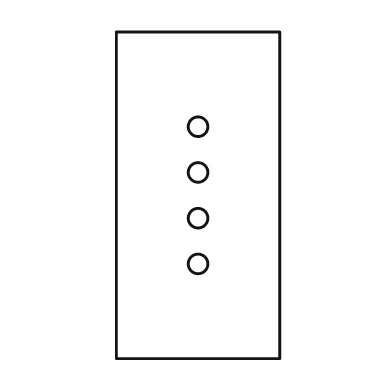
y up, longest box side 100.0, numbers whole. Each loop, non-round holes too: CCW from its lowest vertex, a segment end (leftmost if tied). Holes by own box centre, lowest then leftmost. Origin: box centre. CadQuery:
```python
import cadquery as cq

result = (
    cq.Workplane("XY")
    .moveTo(-25.0, -50.0)
    .lineTo(25.0, -50.0)
    .lineTo(25.0, 50.0)
    .lineTo(-25.0, 50.0)
    .close()
    .moveTo(0.0, -21.0)
    .circle(3.0)
    .moveTo(0.0, -7.0)
    .circle(3.0)
    .moveTo(0.0, 7.0)
    .circle(3.0)
    .moveTo(0.0, 21.0)
    .circle(3.0)
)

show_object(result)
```